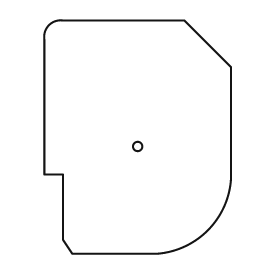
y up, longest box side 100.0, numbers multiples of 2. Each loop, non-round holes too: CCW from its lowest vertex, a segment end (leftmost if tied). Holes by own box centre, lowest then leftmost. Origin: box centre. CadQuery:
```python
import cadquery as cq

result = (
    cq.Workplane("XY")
    .moveTo(-28.0, -50.0)
    .lineTo(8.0, -50.0)
    .threePointArc((30.0, -40.0), (40.0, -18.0))
    .lineTo(40.0, 30.0)
    .lineTo(20.0, 50.0)
    .lineTo(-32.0, 50.0)
    .threePointArc((-38.0, 48.0), (-40.0, 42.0))
    .lineTo(-40.0, -16.0)
    .lineTo(-32.0, -16.0)
    .lineTo(-32.0, -44.0)
    .close()
    .moveTo(0.0, -4.0)
    .circle(2.0)
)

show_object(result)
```